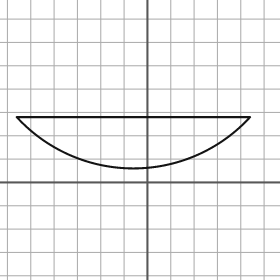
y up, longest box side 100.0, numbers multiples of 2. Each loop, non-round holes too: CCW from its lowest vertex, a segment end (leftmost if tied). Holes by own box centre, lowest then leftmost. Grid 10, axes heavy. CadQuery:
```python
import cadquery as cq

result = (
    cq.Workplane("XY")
    .moveTo(-56.0, 28.0)
    .threePointArc((-6.0, 6.0), (44.0, 28.0))
    .close()
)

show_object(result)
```